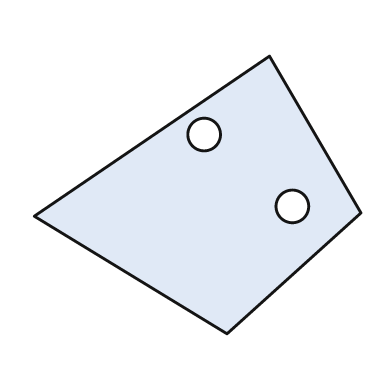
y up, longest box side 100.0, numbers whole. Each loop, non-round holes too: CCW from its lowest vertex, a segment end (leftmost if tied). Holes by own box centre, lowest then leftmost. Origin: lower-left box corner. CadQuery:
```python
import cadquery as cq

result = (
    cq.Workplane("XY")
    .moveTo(59.0, 0.0)
    .lineTo(100.0, 37.0)
    .lineTo(72.0, 85.0)
    .lineTo(0.0, 36.0)
    .close()
    .moveTo(79.0, 39.0)
    .circle(5.0)
    .moveTo(52.0, 61.0)
    .circle(5.0)
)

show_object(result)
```